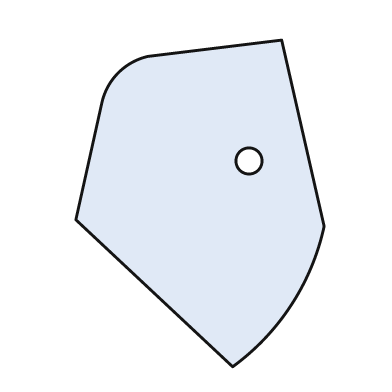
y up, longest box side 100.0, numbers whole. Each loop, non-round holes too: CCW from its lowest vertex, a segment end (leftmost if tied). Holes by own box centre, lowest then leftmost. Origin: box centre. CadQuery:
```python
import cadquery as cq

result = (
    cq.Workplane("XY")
    .moveTo(10.0, -50.0)
    .threePointArc((28.0, -31.0), (38.0, -7.0))
    .lineTo(25.0, 50.0)
    .lineTo(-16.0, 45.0)
    .threePointArc((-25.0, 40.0), (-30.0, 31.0))
    .lineTo(-38.0, -5.0)
    .close()
    .moveTo(15.0, 13.0)
    .circle(4.0)
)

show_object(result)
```